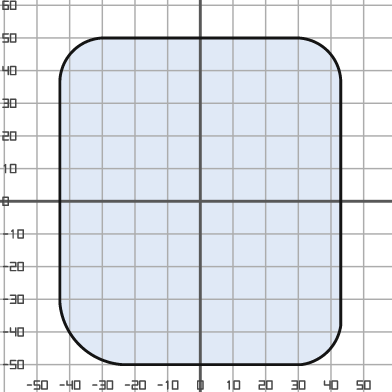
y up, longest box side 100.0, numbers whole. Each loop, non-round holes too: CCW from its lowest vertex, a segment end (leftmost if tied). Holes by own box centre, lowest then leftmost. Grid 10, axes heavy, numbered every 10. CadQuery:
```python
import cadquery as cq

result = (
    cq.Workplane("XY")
    .moveTo(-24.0, -50.0)
    .lineTo(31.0, -50.0)
    .threePointArc((39.0, -46.0), (43.0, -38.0))
    .lineTo(43.0, 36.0)
    .threePointArc((39.0, 46.0), (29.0, 50.0))
    .lineTo(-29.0, 50.0)
    .threePointArc((-39.0, 46.0), (-43.0, 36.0))
    .lineTo(-43.0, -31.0)
    .threePointArc((-37.0, -44.0), (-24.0, -50.0))
    .close()
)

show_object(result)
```